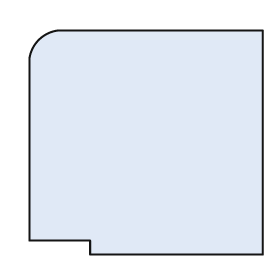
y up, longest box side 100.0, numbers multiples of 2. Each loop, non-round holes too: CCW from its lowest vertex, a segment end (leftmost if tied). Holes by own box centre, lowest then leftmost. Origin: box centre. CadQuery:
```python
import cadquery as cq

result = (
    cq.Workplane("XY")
    .moveTo(-24.0, -48.0)
    .lineTo(50.0, -48.0)
    .lineTo(50.0, 48.0)
    .lineTo(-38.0, 48.0)
    .threePointArc((-46.0, 44.0), (-50.0, 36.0))
    .lineTo(-50.0, -42.0)
    .lineTo(-24.0, -42.0)
    .close()
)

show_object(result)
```